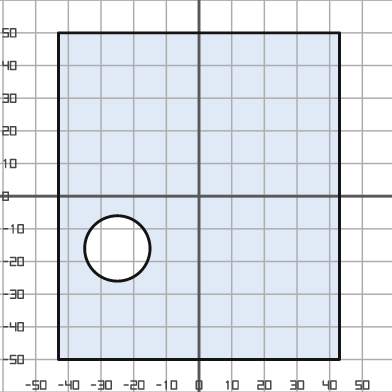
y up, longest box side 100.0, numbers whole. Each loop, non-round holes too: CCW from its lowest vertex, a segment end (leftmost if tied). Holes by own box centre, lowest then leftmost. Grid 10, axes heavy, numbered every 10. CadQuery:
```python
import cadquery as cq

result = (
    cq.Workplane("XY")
    .moveTo(-43.0, -50.0)
    .lineTo(43.0, -50.0)
    .lineTo(43.0, 50.0)
    .lineTo(-43.0, 50.0)
    .close()
    .moveTo(-25.0, -16.0)
    .circle(10.0)
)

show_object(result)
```